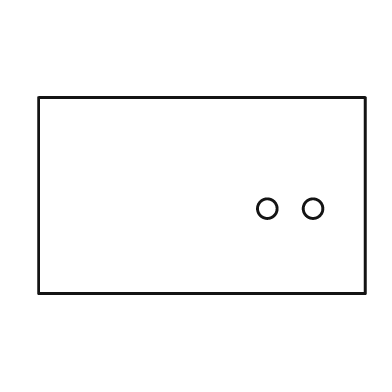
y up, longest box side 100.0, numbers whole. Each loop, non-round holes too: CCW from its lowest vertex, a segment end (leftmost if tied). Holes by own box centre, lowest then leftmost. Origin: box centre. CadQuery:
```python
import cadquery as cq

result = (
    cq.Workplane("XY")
    .moveTo(-50.0, -30.0)
    .lineTo(50.0, -30.0)
    .lineTo(50.0, 30.0)
    .lineTo(-50.0, 30.0)
    .close()
    .moveTo(20.0, -4.0)
    .circle(3.0)
    .moveTo(34.0, -4.0)
    .circle(3.0)
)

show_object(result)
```